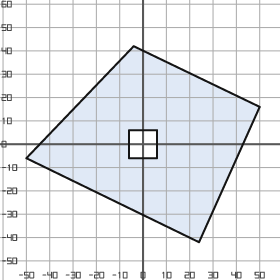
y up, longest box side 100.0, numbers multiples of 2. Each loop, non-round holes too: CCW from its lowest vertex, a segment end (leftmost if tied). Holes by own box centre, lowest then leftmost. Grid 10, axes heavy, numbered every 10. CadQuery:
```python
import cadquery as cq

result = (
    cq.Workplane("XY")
    .moveTo(24.0, -42.0)
    .lineTo(50.0, 16.0)
    .lineTo(-4.0, 42.0)
    .lineTo(-50.0, -6.0)
    .close()
    .moveTo(-6.0, -6.0)
    .lineTo(6.0, -6.0)
    .lineTo(6.0, 6.0)
    .lineTo(-6.0, 6.0)
    .close()
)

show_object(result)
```